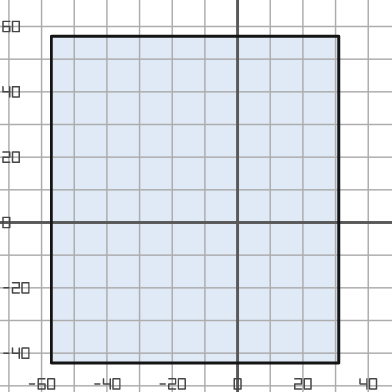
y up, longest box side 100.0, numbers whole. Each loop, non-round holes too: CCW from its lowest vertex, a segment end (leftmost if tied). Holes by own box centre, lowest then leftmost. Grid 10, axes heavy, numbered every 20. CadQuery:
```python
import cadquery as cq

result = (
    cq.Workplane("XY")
    .moveTo(-57.0, -43.0)
    .lineTo(31.0, -43.0)
    .lineTo(31.0, 57.0)
    .lineTo(-57.0, 57.0)
    .close()
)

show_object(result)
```